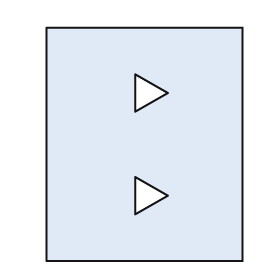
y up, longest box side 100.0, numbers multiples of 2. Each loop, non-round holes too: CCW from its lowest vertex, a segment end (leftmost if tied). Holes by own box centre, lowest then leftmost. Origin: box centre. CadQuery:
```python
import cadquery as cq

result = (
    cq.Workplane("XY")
    .moveTo(-42.0, -50.0)
    .lineTo(42.0, -50.0)
    .lineTo(42.0, 50.0)
    .lineTo(-42.0, 50.0)
    .close()
    .moveTo(-4.0, -30.0)
    .lineTo(10.0, -22.0)
    .lineTo(-4.0, -14.0)
    .close()
    .moveTo(-4.0, 14.0)
    .lineTo(10.0, 22.0)
    .lineTo(-4.0, 30.0)
    .close()
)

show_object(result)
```